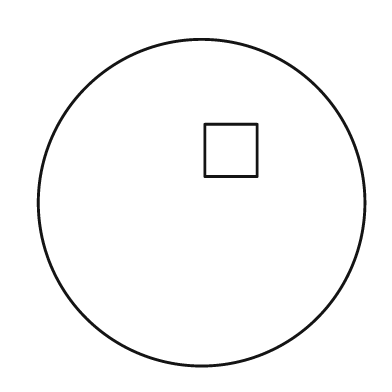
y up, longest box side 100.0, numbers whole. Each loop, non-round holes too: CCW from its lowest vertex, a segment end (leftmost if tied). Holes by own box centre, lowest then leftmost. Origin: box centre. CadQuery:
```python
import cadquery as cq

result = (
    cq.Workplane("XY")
    .moveTo(0.0, 0.0)
    .circle(50.0)
    .moveTo(1.0, 8.0)
    .lineTo(17.0, 8.0)
    .lineTo(17.0, 24.0)
    .lineTo(1.0, 24.0)
    .close()
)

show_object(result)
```